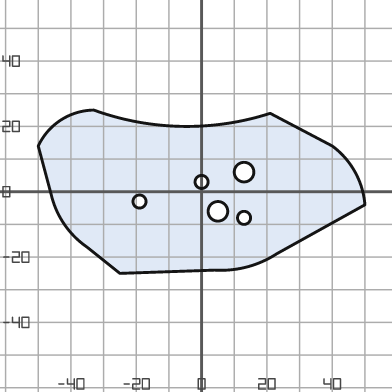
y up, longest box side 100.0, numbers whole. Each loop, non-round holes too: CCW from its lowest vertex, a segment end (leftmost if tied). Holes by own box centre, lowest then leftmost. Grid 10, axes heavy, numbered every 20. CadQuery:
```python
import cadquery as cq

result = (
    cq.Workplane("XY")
    .moveTo(-25.0, -25.0)
    .lineTo(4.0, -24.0)
    .threePointArc((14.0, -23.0), (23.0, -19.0))
    .lineTo(50.0, -4.0)
    .threePointArc((47.0, 6.0), (40.0, 14.0))
    .lineTo(21.0, 24.0)
    .threePointArc((-6.0, 20.0), (-33.0, 25.0))
    .threePointArc((-43.0, 22.0), (-50.0, 14.0))
    .lineTo(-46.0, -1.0)
    .threePointArc((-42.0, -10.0), (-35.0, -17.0))
    .close()
    .moveTo(13.0, -8.0)
    .circle(2.0)
    .moveTo(5.0, -6.0)
    .circle(3.0)
    .moveTo(-19.0, -3.0)
    .circle(2.0)
    .moveTo(0.0, 3.0)
    .circle(2.0)
    .moveTo(13.0, 6.0)
    .circle(3.0)
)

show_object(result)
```